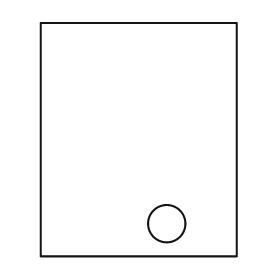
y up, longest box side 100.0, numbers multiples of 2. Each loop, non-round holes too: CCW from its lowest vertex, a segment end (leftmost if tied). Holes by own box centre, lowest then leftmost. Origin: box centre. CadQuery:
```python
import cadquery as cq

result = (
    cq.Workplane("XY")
    .moveTo(-42.0, -50.0)
    .lineTo(42.0, -50.0)
    .lineTo(42.0, 50.0)
    .lineTo(-42.0, 50.0)
    .close()
    .moveTo(12.0, -36.0)
    .circle(8.0)
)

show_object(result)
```